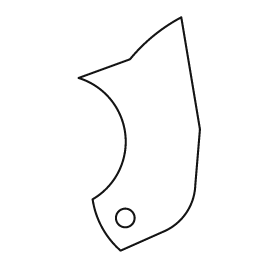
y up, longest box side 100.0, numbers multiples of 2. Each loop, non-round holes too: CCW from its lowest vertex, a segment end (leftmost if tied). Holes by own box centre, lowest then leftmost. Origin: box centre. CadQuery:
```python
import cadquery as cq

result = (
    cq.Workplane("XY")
    .moveTo(-8.0, -50.0)
    .lineTo(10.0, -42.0)
    .threePointArc((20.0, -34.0), (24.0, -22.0))
    .lineTo(26.0, 2.0)
    .lineTo(18.0, 50.0)
    .threePointArc((6.0, 42.0), (-4.0, 32.0))
    .lineTo(-26.0, 24.0)
    .threePointArc((-6.0, 0.0), (-20.0, -28.0))
    .threePointArc((-16.0, -40.0), (-8.0, -50.0))
    .close()
    .moveTo(-6.0, -36.0)
    .circle(4.0)
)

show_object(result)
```